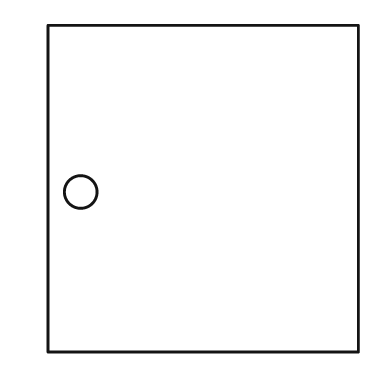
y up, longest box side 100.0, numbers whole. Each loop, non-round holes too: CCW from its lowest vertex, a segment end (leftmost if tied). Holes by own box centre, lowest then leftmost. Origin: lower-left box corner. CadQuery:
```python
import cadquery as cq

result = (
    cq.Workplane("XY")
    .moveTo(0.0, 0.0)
    .lineTo(95.0, 0.0)
    .lineTo(95.0, 100.0)
    .lineTo(0.0, 100.0)
    .close()
    .moveTo(10.0, 49.0)
    .circle(5.0)
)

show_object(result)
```